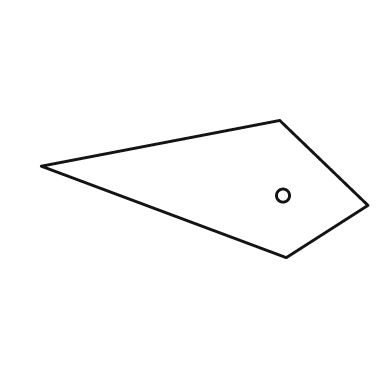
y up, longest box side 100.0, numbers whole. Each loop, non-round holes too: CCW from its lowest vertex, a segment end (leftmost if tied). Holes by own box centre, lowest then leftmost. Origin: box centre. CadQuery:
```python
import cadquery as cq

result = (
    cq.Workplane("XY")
    .moveTo(25.0, -21.0)
    .lineTo(50.0, -5.0)
    .lineTo(23.0, 21.0)
    .lineTo(-50.0, 7.0)
    .close()
    .moveTo(24.0, -2.0)
    .circle(2.0)
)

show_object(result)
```